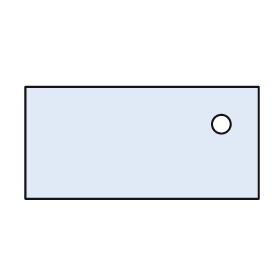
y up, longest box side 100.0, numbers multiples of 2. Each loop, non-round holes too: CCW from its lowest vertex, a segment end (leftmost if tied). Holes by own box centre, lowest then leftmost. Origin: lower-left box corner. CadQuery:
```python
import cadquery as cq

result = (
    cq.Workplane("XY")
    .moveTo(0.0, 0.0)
    .lineTo(100.0, 0.0)
    .lineTo(100.0, 48.0)
    .lineTo(0.0, 48.0)
    .close()
    .moveTo(84.0, 32.0)
    .circle(4.0)
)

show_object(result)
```